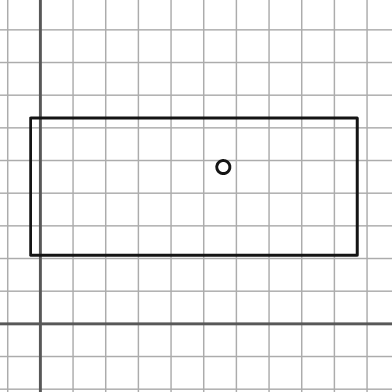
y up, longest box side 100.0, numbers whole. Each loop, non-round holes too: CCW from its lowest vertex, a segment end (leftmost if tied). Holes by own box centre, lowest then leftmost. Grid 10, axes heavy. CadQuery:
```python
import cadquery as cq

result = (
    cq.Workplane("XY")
    .moveTo(-3.0, 21.0)
    .lineTo(97.0, 21.0)
    .lineTo(97.0, 63.0)
    .lineTo(-3.0, 63.0)
    .close()
    .moveTo(56.0, 48.0)
    .circle(2.0)
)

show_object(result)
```